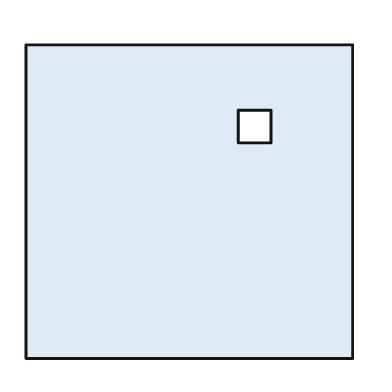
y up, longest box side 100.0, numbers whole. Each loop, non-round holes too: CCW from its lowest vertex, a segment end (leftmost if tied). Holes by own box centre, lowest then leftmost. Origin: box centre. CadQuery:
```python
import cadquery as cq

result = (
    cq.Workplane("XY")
    .moveTo(-50.0, -48.0)
    .lineTo(50.0, -48.0)
    .lineTo(50.0, 48.0)
    .lineTo(-50.0, 48.0)
    .close()
    .moveTo(15.0, 18.0)
    .lineTo(25.0, 18.0)
    .lineTo(25.0, 28.0)
    .lineTo(15.0, 28.0)
    .close()
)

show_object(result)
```